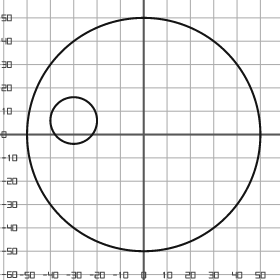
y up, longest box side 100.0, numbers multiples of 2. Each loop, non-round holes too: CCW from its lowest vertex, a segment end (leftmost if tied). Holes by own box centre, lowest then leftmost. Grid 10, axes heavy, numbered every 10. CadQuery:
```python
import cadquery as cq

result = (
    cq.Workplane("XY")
    .moveTo(0.0, 0.0)
    .circle(50.0)
    .moveTo(-30.0, 6.0)
    .circle(10.0)
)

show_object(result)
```